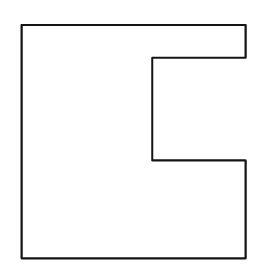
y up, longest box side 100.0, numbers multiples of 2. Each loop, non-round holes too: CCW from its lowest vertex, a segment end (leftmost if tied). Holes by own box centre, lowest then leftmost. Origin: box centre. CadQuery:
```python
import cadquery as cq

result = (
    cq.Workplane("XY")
    .moveTo(-48.0, -50.0)
    .lineTo(48.0, -50.0)
    .lineTo(48.0, -8.0)
    .lineTo(8.0, -8.0)
    .lineTo(8.0, 36.0)
    .lineTo(48.0, 36.0)
    .lineTo(48.0, 50.0)
    .lineTo(-48.0, 50.0)
    .close()
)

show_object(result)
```